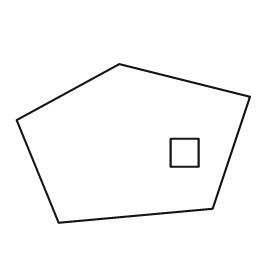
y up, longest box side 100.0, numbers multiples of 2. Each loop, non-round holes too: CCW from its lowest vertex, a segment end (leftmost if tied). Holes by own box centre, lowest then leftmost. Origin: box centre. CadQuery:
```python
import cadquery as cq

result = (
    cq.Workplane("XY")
    .moveTo(-32.0, -34.0)
    .lineTo(34.0, -28.0)
    .lineTo(50.0, 20.0)
    .lineTo(-6.0, 34.0)
    .lineTo(-50.0, 10.0)
    .close()
    .moveTo(16.0, -10.0)
    .lineTo(28.0, -10.0)
    .lineTo(28.0, 2.0)
    .lineTo(16.0, 2.0)
    .close()
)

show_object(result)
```